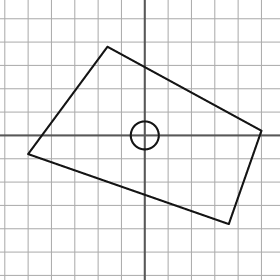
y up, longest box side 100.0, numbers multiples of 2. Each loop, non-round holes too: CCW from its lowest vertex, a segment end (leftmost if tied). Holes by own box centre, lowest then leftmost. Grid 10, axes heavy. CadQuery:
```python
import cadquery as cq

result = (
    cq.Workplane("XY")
    .moveTo(36.0, -38.0)
    .lineTo(50.0, 2.0)
    .lineTo(-16.0, 38.0)
    .lineTo(-50.0, -8.0)
    .close()
    .moveTo(0.0, 0.0)
    .circle(6.0)
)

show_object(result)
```